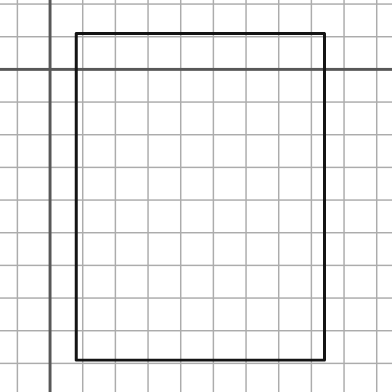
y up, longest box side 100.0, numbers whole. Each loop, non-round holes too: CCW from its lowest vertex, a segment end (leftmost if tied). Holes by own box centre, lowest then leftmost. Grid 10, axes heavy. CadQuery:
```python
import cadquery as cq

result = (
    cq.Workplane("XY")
    .moveTo(8.0, -89.0)
    .lineTo(84.0, -89.0)
    .lineTo(84.0, 11.0)
    .lineTo(8.0, 11.0)
    .close()
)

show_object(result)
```